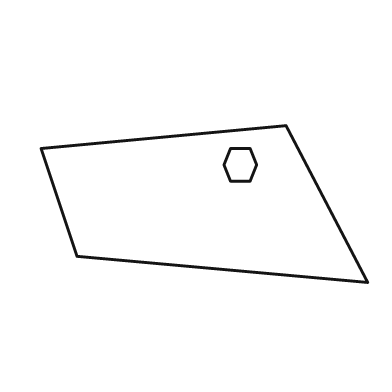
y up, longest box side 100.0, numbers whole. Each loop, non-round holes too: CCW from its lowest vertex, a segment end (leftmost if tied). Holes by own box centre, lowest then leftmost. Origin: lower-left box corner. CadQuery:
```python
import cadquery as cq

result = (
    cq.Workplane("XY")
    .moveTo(100.0, 0.0)
    .lineTo(75.0, 48.0)
    .lineTo(0.0, 41.0)
    .lineTo(11.0, 8.0)
    .close()
    .moveTo(58.0, 31.0)
    .lineTo(64.0, 31.0)
    .lineTo(66.0, 36.0)
    .lineTo(64.0, 41.0)
    .lineTo(58.0, 41.0)
    .lineTo(56.0, 36.0)
    .close()
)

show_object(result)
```